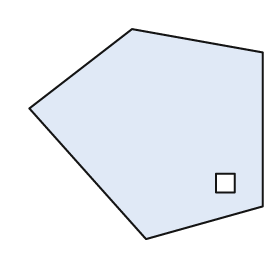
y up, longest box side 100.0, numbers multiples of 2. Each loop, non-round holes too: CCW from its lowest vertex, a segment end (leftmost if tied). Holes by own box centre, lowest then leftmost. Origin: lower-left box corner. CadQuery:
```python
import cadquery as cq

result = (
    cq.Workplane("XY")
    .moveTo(50.0, 0.0)
    .lineTo(100.0, 14.0)
    .lineTo(100.0, 80.0)
    .lineTo(44.0, 90.0)
    .lineTo(0.0, 56.0)
    .close()
    .moveTo(80.0, 20.0)
    .lineTo(88.0, 20.0)
    .lineTo(88.0, 28.0)
    .lineTo(80.0, 28.0)
    .close()
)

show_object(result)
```